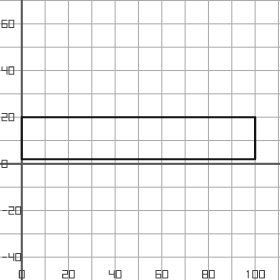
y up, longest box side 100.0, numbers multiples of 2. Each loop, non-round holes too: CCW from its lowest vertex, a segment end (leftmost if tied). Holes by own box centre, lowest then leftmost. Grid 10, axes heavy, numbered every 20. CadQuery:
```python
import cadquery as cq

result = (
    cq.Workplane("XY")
    .moveTo(0.0, 2.0)
    .lineTo(100.0, 2.0)
    .lineTo(100.0, 20.0)
    .lineTo(0.0, 20.0)
    .close()
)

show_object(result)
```